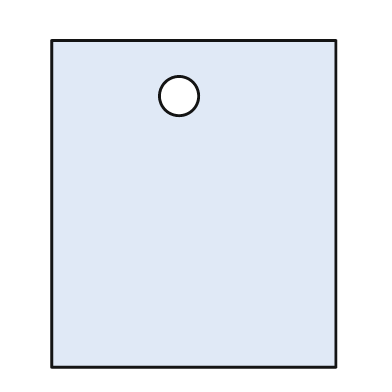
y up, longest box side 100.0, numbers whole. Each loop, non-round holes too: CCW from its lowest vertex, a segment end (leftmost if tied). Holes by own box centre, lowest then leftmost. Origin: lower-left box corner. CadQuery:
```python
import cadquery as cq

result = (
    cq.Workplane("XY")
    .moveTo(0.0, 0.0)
    .lineTo(87.0, 0.0)
    .lineTo(87.0, 100.0)
    .lineTo(0.0, 100.0)
    .close()
    .moveTo(39.0, 83.0)
    .circle(6.0)
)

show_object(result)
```